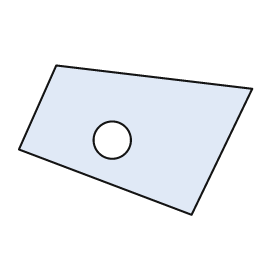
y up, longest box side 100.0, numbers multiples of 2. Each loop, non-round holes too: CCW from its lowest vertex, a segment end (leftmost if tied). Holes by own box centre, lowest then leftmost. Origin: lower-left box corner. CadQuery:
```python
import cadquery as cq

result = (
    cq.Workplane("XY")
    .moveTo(74.0, 0.0)
    .lineTo(100.0, 54.0)
    .lineTo(16.0, 64.0)
    .lineTo(0.0, 28.0)
    .close()
    .moveTo(40.0, 32.0)
    .circle(8.0)
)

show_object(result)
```